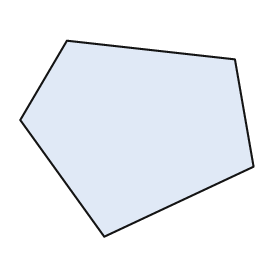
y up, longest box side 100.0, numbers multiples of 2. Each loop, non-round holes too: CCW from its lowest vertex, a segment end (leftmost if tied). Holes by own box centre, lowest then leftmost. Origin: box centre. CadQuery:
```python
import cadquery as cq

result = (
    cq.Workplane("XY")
    .moveTo(-14.0, -42.0)
    .lineTo(50.0, -12.0)
    .lineTo(42.0, 34.0)
    .lineTo(-30.0, 42.0)
    .lineTo(-50.0, 8.0)
    .close()
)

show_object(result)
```